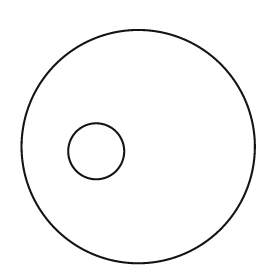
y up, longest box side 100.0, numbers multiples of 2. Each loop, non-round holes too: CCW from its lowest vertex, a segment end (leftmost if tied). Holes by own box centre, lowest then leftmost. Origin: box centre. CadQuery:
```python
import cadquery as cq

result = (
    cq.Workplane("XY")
    .moveTo(0.0, 0.0)
    .circle(50.0)
    .moveTo(-18.0, -2.0)
    .circle(12.0)
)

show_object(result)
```